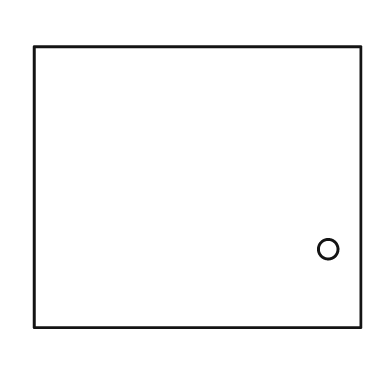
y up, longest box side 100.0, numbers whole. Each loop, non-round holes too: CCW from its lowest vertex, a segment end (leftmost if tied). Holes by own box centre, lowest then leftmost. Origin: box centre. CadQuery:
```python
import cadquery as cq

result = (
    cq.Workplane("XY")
    .moveTo(-50.0, -43.0)
    .lineTo(50.0, -43.0)
    .lineTo(50.0, 43.0)
    .lineTo(-50.0, 43.0)
    .close()
    .moveTo(40.0, -19.0)
    .circle(3.0)
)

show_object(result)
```